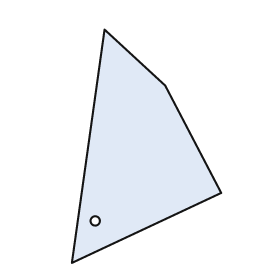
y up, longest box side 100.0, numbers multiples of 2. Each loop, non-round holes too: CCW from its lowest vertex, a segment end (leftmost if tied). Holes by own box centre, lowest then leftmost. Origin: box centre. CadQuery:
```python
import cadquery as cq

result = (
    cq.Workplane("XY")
    .moveTo(-32.0, -50.0)
    .lineTo(32.0, -20.0)
    .lineTo(8.0, 26.0)
    .lineTo(-18.0, 50.0)
    .close()
    .moveTo(-22.0, -32.0)
    .circle(2.0)
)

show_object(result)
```